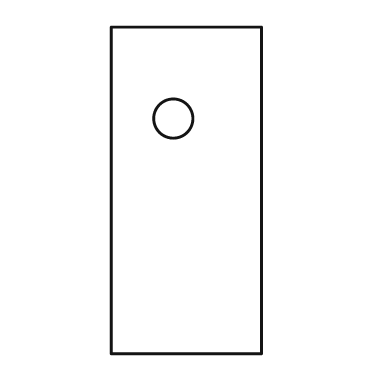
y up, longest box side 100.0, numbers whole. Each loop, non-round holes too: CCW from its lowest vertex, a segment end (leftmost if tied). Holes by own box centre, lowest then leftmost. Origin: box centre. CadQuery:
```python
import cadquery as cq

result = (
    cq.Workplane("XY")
    .moveTo(-23.0, -50.0)
    .lineTo(23.0, -50.0)
    .lineTo(23.0, 50.0)
    .lineTo(-23.0, 50.0)
    .close()
    .moveTo(-4.0, 22.0)
    .circle(6.0)
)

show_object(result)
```